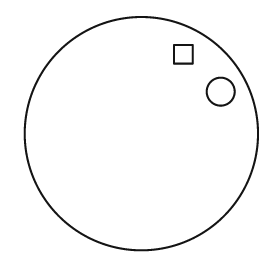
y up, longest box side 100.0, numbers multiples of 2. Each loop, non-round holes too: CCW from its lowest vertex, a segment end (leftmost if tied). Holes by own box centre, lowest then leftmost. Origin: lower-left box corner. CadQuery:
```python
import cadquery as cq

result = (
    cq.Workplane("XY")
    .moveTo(50.0, 50.0)
    .circle(50.0)
    .moveTo(84.0, 68.0)
    .circle(6.0)
    .moveTo(64.0, 80.0)
    .lineTo(72.0, 80.0)
    .lineTo(72.0, 88.0)
    .lineTo(64.0, 88.0)
    .close()
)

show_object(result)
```